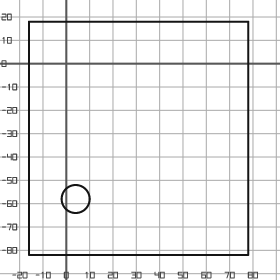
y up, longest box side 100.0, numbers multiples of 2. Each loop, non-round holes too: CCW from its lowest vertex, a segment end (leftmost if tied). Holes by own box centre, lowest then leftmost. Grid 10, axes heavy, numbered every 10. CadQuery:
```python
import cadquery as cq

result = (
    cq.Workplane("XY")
    .moveTo(-16.0, -82.0)
    .lineTo(78.0, -82.0)
    .lineTo(78.0, 18.0)
    .lineTo(-16.0, 18.0)
    .close()
    .moveTo(4.0, -58.0)
    .circle(6.0)
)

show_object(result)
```